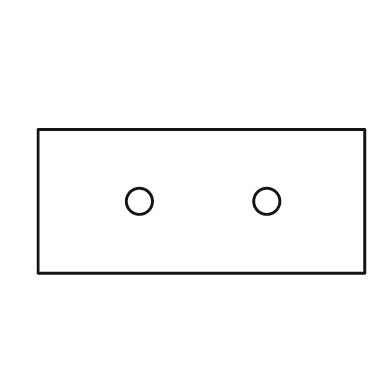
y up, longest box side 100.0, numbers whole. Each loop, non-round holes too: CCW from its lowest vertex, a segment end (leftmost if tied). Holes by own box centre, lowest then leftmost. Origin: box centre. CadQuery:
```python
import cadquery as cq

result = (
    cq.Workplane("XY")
    .moveTo(-50.0, -22.0)
    .lineTo(50.0, -22.0)
    .lineTo(50.0, 22.0)
    .lineTo(-50.0, 22.0)
    .close()
    .moveTo(-19.0, 0.0)
    .circle(4.0)
    .moveTo(20.0, 0.0)
    .circle(4.0)
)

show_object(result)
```